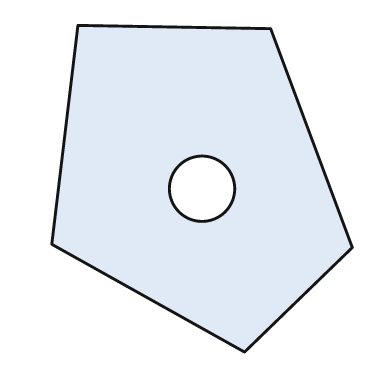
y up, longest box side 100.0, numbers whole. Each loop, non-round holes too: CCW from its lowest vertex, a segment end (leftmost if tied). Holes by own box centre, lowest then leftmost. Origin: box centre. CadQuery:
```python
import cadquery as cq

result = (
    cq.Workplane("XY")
    .moveTo(13.0, -50.0)
    .lineTo(46.0, -18.0)
    .lineTo(21.0, 49.0)
    .lineTo(-38.0, 50.0)
    .lineTo(-46.0, -17.0)
    .close()
    .moveTo(0.0, 0.0)
    .circle(10.0)
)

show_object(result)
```